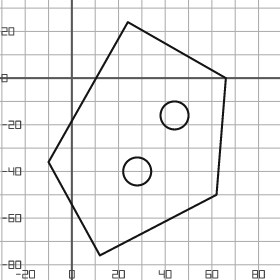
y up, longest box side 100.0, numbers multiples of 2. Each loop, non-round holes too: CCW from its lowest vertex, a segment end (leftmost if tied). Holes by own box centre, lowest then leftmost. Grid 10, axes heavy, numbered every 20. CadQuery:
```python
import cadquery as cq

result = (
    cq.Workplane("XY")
    .moveTo(12.0, -76.0)
    .lineTo(62.0, -50.0)
    .lineTo(66.0, 0.0)
    .lineTo(24.0, 24.0)
    .lineTo(-10.0, -36.0)
    .close()
    .moveTo(28.0, -40.0)
    .circle(6.0)
    .moveTo(44.0, -16.0)
    .circle(6.0)
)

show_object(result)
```